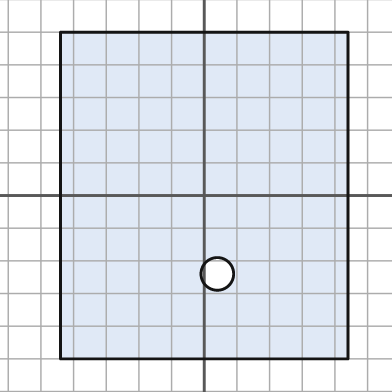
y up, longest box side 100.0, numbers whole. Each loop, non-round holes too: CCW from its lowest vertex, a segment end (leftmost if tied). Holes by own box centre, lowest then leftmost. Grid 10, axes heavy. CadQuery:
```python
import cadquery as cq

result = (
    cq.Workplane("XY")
    .moveTo(-44.0, -50.0)
    .lineTo(44.0, -50.0)
    .lineTo(44.0, 50.0)
    .lineTo(-44.0, 50.0)
    .close()
    .moveTo(4.0, -24.0)
    .circle(5.0)
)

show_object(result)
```